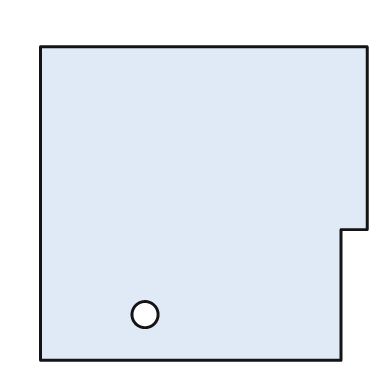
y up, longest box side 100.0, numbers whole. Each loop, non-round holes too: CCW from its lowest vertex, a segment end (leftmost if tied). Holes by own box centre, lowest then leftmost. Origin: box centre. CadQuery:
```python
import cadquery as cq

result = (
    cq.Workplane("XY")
    .moveTo(-50.0, -48.0)
    .lineTo(42.0, -48.0)
    .lineTo(42.0, -8.0)
    .lineTo(50.0, -8.0)
    .lineTo(50.0, 48.0)
    .lineTo(-50.0, 48.0)
    .close()
    .moveTo(-18.0, -34.0)
    .circle(4.0)
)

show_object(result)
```